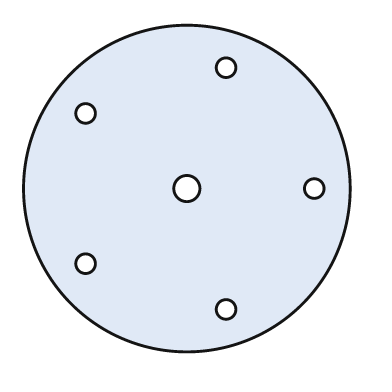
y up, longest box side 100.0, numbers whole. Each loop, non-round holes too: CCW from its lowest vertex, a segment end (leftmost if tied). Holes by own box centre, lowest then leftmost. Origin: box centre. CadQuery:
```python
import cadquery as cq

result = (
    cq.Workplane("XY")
    .moveTo(0.0, 0.0)
    .circle(50.0)
    .moveTo(12.0, -37.0)
    .circle(3.0)
    .moveTo(-31.0, -23.0)
    .circle(3.0)
    .moveTo(0.0, 0.0)
    .circle(4.0)
    .moveTo(39.0, 0.0)
    .circle(3.0)
    .moveTo(-31.0, 23.0)
    .circle(3.0)
    .moveTo(12.0, 37.0)
    .circle(3.0)
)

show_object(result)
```